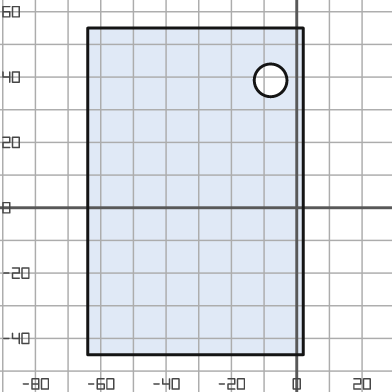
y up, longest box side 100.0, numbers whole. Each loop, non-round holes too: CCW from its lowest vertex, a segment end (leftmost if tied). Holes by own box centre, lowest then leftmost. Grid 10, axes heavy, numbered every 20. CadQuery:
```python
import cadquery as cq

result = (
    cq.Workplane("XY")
    .moveTo(-64.0, -45.0)
    .lineTo(2.0, -45.0)
    .lineTo(2.0, 55.0)
    .lineTo(-64.0, 55.0)
    .close()
    .moveTo(-8.0, 39.0)
    .circle(5.0)
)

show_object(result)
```